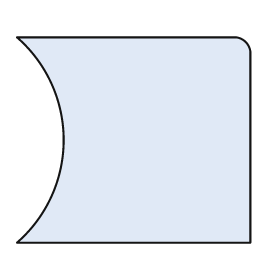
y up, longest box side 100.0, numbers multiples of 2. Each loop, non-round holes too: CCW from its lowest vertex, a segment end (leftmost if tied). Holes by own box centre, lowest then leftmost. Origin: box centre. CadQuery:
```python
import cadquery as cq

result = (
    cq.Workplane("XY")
    .moveTo(-50.0, -44.0)
    .lineTo(50.0, -44.0)
    .lineTo(50.0, 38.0)
    .threePointArc((48.0, 42.0), (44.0, 44.0))
    .lineTo(-50.0, 44.0)
    .threePointArc((-30.0, 0.0), (-50.0, -44.0))
    .close()
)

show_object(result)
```